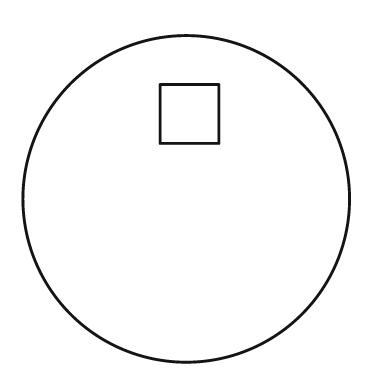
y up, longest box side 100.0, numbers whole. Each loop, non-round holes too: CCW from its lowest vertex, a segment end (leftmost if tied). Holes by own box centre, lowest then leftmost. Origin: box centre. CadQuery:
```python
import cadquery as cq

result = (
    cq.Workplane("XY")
    .moveTo(0.0, 0.0)
    .circle(50.0)
    .moveTo(-8.0, 17.0)
    .lineTo(10.0, 17.0)
    .lineTo(10.0, 35.0)
    .lineTo(-8.0, 35.0)
    .close()
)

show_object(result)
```